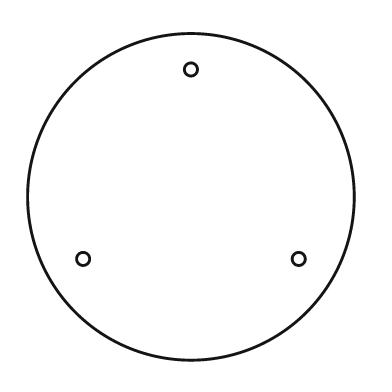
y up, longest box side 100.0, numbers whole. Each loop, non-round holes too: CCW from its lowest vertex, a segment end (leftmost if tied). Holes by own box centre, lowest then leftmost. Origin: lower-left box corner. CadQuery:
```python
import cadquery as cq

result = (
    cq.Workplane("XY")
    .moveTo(50.0, 50.0)
    .circle(50.0)
    .moveTo(17.0, 31.0)
    .circle(2.0)
    .moveTo(83.0, 31.0)
    .circle(2.0)
    .moveTo(50.0, 89.0)
    .circle(2.0)
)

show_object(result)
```